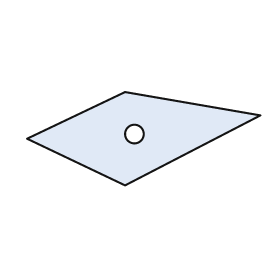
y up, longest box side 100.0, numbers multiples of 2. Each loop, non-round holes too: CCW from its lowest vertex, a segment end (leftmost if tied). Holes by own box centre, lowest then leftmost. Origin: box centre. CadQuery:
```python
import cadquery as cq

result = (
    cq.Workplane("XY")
    .moveTo(-8.0, -20.0)
    .lineTo(50.0, 10.0)
    .lineTo(-8.0, 20.0)
    .lineTo(-50.0, 0.0)
    .close()
    .moveTo(-4.0, 2.0)
    .circle(4.0)
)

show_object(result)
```